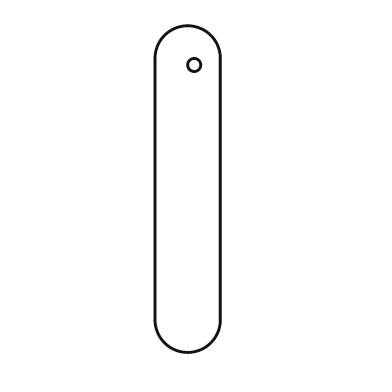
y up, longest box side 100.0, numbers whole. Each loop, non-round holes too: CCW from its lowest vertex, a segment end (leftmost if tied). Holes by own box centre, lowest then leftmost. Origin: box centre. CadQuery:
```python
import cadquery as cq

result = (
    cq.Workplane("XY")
    .moveTo(-10.0, -40.0)
    .threePointArc((0.0, -50.0), (10.0, -40.0))
    .lineTo(10.0, 40.0)
    .threePointArc((0.0, 50.0), (-10.0, 40.0))
    .close()
    .moveTo(2.0, 38.0)
    .circle(2.0)
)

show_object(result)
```